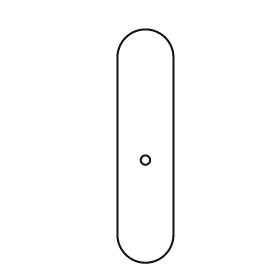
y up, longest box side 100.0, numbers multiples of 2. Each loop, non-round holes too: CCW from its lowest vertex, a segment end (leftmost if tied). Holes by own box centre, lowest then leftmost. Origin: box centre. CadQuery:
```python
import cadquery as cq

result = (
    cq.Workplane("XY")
    .moveTo(-12.0, -38.0)
    .threePointArc((0.0, -50.0), (12.0, -38.0))
    .lineTo(12.0, 38.0)
    .threePointArc((0.0, 50.0), (-12.0, 38.0))
    .close()
    .moveTo(0.0, -6.0)
    .circle(2.0)
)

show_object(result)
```